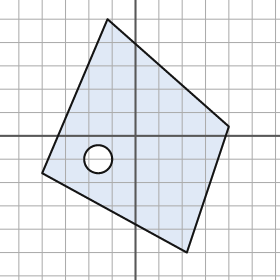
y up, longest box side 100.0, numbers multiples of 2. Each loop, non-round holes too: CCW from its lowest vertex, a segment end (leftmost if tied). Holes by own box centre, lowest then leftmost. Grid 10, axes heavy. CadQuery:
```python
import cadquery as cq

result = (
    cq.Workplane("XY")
    .moveTo(22.0, -50.0)
    .lineTo(40.0, 4.0)
    .lineTo(-12.0, 50.0)
    .lineTo(-40.0, -16.0)
    .close()
    .moveTo(-16.0, -10.0)
    .circle(6.0)
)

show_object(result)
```